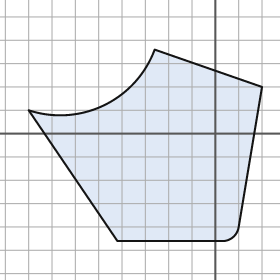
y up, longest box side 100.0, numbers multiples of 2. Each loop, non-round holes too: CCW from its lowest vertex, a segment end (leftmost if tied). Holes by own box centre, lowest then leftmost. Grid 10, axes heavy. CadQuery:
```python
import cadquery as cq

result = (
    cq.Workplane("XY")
    .moveTo(-42.0, -46.0)
    .lineTo(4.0, -46.0)
    .threePointArc((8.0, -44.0), (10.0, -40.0))
    .lineTo(20.0, 20.0)
    .lineTo(-26.0, 36.0)
    .threePointArc((-48.0, 12.0), (-80.0, 10.0))
    .close()
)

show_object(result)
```